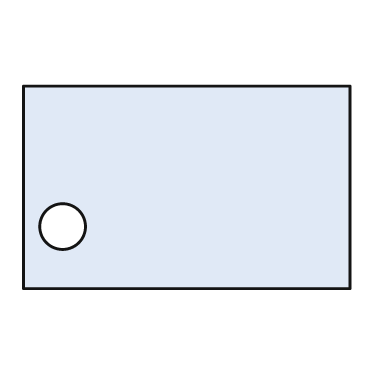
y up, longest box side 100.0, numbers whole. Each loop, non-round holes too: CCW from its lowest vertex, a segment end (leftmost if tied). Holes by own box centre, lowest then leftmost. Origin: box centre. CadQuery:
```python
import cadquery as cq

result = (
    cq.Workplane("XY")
    .moveTo(-50.0, -31.0)
    .lineTo(50.0, -31.0)
    .lineTo(50.0, 31.0)
    .lineTo(-50.0, 31.0)
    .close()
    .moveTo(-38.0, -12.0)
    .circle(7.0)
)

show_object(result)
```